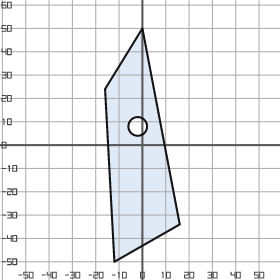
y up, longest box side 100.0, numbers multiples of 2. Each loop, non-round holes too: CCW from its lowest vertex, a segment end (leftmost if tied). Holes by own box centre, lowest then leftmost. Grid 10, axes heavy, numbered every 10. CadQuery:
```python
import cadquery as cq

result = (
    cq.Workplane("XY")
    .moveTo(-12.0, -50.0)
    .lineTo(16.0, -34.0)
    .lineTo(0.0, 50.0)
    .lineTo(-16.0, 24.0)
    .close()
    .moveTo(-2.0, 8.0)
    .circle(4.0)
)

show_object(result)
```